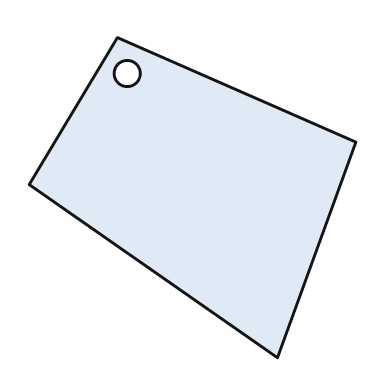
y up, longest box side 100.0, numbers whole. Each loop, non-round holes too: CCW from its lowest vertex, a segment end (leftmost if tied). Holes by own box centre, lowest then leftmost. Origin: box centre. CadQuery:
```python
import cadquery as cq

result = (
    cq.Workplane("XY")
    .moveTo(26.0, -49.0)
    .lineTo(50.0, 17.0)
    .lineTo(-23.0, 49.0)
    .lineTo(-50.0, 4.0)
    .close()
    .moveTo(-20.0, 38.0)
    .circle(4.0)
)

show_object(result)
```